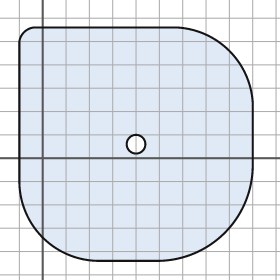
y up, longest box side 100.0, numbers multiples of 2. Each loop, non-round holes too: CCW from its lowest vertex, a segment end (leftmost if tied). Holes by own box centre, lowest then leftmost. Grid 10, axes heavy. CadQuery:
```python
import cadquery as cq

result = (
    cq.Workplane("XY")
    .moveTo(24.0, -44.0)
    .lineTo(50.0, -44.0)
    .threePointArc((78.0, -32.0), (90.0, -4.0))
    .lineTo(90.0, 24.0)
    .threePointArc((80.0, 46.0), (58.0, 56.0))
    .lineTo(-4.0, 56.0)
    .threePointArc((-8.0, 54.0), (-10.0, 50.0))
    .lineTo(-10.0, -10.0)
    .threePointArc((0.0, -34.0), (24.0, -44.0))
    .close()
    .moveTo(40.0, 6.0)
    .circle(4.0)
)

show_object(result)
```